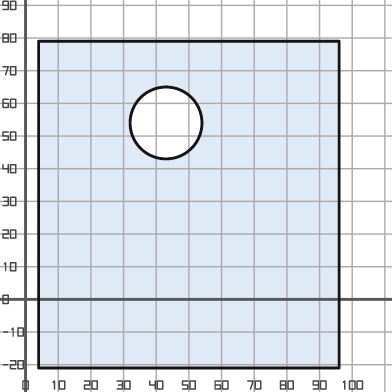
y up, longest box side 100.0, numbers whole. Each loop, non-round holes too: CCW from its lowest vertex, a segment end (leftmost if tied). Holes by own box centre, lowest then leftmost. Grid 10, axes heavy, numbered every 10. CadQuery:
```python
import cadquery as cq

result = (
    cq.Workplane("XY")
    .moveTo(4.0, -21.0)
    .lineTo(96.0, -21.0)
    .lineTo(96.0, 79.0)
    .lineTo(4.0, 79.0)
    .close()
    .moveTo(43.0, 54.0)
    .circle(11.0)
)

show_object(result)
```